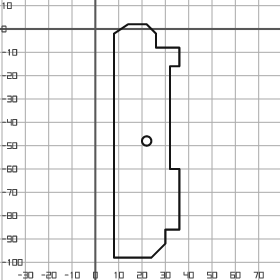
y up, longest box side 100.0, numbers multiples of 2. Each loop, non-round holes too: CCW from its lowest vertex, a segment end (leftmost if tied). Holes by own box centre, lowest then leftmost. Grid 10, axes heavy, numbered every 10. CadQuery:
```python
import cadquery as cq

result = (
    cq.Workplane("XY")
    .moveTo(8.0, -98.0)
    .lineTo(24.0, -98.0)
    .lineTo(30.0, -92.0)
    .lineTo(30.0, -86.0)
    .lineTo(36.0, -86.0)
    .lineTo(36.0, -60.0)
    .lineTo(32.0, -60.0)
    .lineTo(32.0, -16.0)
    .lineTo(36.0, -16.0)
    .lineTo(36.0, -8.0)
    .lineTo(26.0, -8.0)
    .lineTo(26.0, -2.0)
    .lineTo(22.0, 2.0)
    .lineTo(14.0, 2.0)
    .lineTo(8.0, -2.0)
    .close()
    .moveTo(22.0, -48.0)
    .circle(2.0)
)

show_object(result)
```